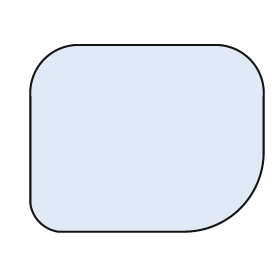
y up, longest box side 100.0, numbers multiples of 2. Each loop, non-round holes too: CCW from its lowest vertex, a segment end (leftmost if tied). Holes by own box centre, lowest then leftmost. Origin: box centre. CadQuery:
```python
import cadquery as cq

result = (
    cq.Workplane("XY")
    .moveTo(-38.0, -40.0)
    .lineTo(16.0, -40.0)
    .threePointArc((40.0, -30.0), (50.0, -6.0))
    .lineTo(50.0, 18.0)
    .threePointArc((44.0, 34.0), (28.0, 40.0))
    .lineTo(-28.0, 40.0)
    .threePointArc((-44.0, 34.0), (-50.0, 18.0))
    .lineTo(-50.0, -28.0)
    .threePointArc((-46.0, -36.0), (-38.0, -40.0))
    .close()
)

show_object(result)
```